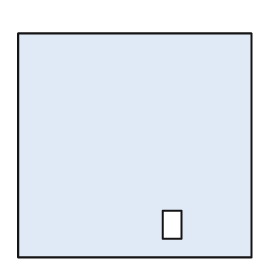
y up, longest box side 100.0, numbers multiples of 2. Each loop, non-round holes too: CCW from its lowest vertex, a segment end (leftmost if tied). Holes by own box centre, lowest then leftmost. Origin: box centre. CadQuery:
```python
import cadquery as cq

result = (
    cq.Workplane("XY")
    .moveTo(-50.0, -48.0)
    .lineTo(50.0, -48.0)
    .lineTo(50.0, 48.0)
    .lineTo(-50.0, 48.0)
    .close()
    .moveTo(12.0, -40.0)
    .lineTo(20.0, -40.0)
    .lineTo(20.0, -28.0)
    .lineTo(12.0, -28.0)
    .close()
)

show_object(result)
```